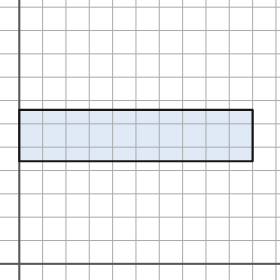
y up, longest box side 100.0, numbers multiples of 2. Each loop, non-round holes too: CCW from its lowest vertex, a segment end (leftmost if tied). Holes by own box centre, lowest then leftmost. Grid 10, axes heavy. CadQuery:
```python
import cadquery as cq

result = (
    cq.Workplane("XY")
    .moveTo(0.0, 44.0)
    .lineTo(100.0, 44.0)
    .lineTo(100.0, 66.0)
    .lineTo(0.0, 66.0)
    .close()
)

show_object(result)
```